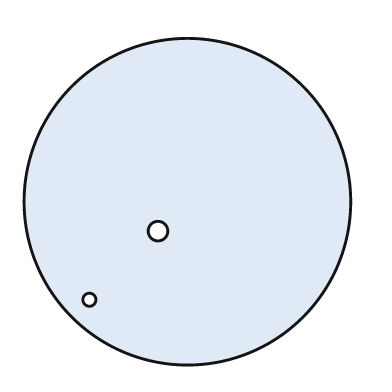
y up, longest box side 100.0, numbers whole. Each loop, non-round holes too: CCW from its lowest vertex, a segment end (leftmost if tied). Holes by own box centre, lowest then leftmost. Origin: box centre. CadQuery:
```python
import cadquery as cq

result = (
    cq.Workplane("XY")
    .moveTo(0.0, 0.0)
    .circle(50.0)
    .moveTo(-30.0, -30.0)
    .circle(2.0)
    .moveTo(-9.0, -9.0)
    .circle(3.0)
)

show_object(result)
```